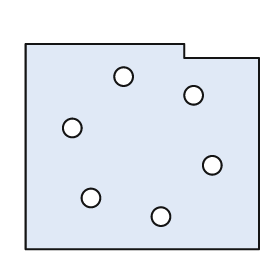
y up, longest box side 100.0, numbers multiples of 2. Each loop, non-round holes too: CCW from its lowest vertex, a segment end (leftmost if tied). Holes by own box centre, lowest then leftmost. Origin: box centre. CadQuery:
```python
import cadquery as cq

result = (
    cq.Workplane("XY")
    .moveTo(-50.0, -44.0)
    .lineTo(50.0, -44.0)
    .lineTo(50.0, 38.0)
    .lineTo(18.0, 38.0)
    .lineTo(18.0, 44.0)
    .lineTo(-50.0, 44.0)
    .close()
    .moveTo(8.0, -30.0)
    .circle(4.0)
    .moveTo(-22.0, -22.0)
    .circle(4.0)
    .moveTo(30.0, -8.0)
    .circle(4.0)
    .moveTo(-30.0, 8.0)
    .circle(4.0)
    .moveTo(22.0, 22.0)
    .circle(4.0)
    .moveTo(-8.0, 30.0)
    .circle(4.0)
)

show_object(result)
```